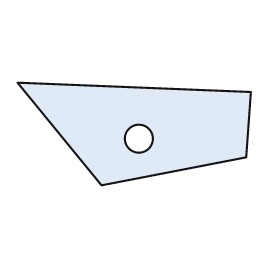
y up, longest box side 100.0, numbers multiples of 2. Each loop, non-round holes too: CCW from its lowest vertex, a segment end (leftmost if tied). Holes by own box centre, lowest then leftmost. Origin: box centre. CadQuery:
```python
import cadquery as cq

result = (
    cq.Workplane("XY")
    .moveTo(-14.0, -22.0)
    .lineTo(48.0, -10.0)
    .lineTo(50.0, 18.0)
    .lineTo(-50.0, 22.0)
    .close()
    .moveTo(2.0, -2.0)
    .circle(6.0)
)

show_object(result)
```